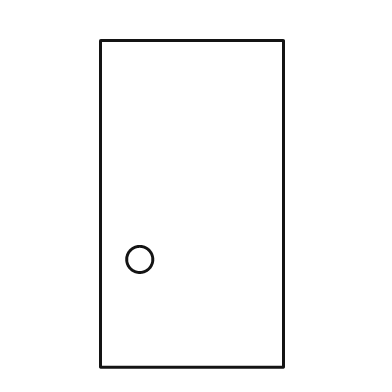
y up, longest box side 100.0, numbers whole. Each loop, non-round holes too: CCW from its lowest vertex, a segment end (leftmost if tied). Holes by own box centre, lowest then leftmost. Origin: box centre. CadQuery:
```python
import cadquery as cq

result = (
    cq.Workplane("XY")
    .moveTo(-28.0, -50.0)
    .lineTo(28.0, -50.0)
    .lineTo(28.0, 50.0)
    .lineTo(-28.0, 50.0)
    .close()
    .moveTo(-16.0, -17.0)
    .circle(4.0)
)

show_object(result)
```